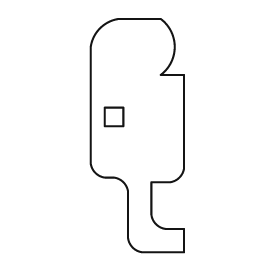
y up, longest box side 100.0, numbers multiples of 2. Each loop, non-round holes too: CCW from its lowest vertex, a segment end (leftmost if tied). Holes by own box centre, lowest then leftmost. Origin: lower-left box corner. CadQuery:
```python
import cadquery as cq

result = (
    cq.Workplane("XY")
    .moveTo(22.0, 0.0)
    .lineTo(40.0, 0.0)
    .lineTo(40.0, 10.0)
    .lineTo(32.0, 10.0)
    .threePointArc((28.0, 12.0), (26.0, 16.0))
    .lineTo(26.0, 30.0)
    .lineTo(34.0, 30.0)
    .threePointArc((38.0, 32.0), (40.0, 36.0))
    .lineTo(40.0, 76.0)
    .lineTo(30.0, 76.0)
    .threePointArc((36.0, 88.0), (30.0, 100.0))
    .lineTo(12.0, 100.0)
    .threePointArc((4.0, 96.0), (0.0, 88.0))
    .lineTo(0.0, 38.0)
    .threePointArc((2.0, 34.0), (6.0, 32.0))
    .lineTo(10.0, 32.0)
    .threePointArc((14.0, 30.0), (16.0, 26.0))
    .lineTo(16.0, 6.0)
    .threePointArc((18.0, 2.0), (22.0, 0.0))
    .close()
    .moveTo(6.0, 54.0)
    .lineTo(14.0, 54.0)
    .lineTo(14.0, 62.0)
    .lineTo(6.0, 62.0)
    .close()
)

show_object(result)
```